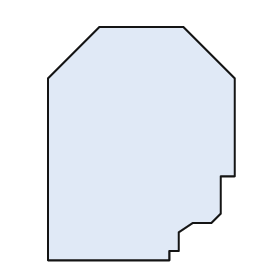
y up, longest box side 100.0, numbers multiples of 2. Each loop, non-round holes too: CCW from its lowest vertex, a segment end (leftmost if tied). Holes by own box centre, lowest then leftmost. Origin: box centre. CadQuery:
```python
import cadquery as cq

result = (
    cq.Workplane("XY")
    .moveTo(-40.0, -50.0)
    .lineTo(12.0, -50.0)
    .lineTo(12.0, -46.0)
    .lineTo(16.0, -46.0)
    .lineTo(16.0, -38.0)
    .lineTo(22.0, -34.0)
    .lineTo(30.0, -34.0)
    .lineTo(34.0, -30.0)
    .lineTo(34.0, -14.0)
    .lineTo(40.0, -14.0)
    .lineTo(40.0, 28.0)
    .lineTo(18.0, 50.0)
    .lineTo(-18.0, 50.0)
    .lineTo(-40.0, 28.0)
    .close()
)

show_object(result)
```